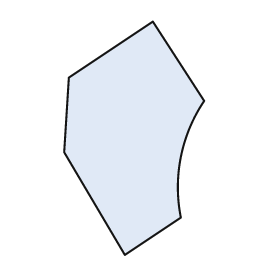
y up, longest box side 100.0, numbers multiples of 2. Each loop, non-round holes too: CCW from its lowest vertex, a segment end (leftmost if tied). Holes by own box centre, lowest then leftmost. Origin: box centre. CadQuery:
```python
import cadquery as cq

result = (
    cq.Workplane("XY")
    .moveTo(-4.0, -50.0)
    .lineTo(20.0, -34.0)
    .threePointArc((20.0, -8.0), (30.0, 16.0))
    .lineTo(8.0, 50.0)
    .lineTo(-28.0, 26.0)
    .lineTo(-30.0, -6.0)
    .close()
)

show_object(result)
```